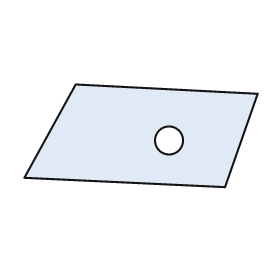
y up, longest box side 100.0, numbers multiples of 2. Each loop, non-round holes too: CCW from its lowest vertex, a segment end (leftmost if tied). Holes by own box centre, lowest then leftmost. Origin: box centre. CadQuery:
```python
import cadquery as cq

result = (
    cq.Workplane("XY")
    .moveTo(36.0, -22.0)
    .lineTo(50.0, 18.0)
    .lineTo(-28.0, 22.0)
    .lineTo(-50.0, -18.0)
    .close()
    .moveTo(12.0, -2.0)
    .circle(6.0)
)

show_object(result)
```